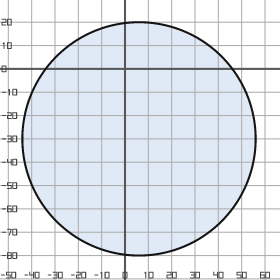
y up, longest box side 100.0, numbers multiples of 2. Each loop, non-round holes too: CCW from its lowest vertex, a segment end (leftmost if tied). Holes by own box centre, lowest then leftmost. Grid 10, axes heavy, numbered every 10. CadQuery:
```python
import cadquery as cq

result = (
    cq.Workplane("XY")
    .moveTo(6.0, -30.0)
    .circle(50.0)
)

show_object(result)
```